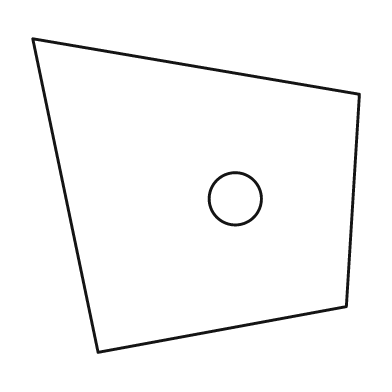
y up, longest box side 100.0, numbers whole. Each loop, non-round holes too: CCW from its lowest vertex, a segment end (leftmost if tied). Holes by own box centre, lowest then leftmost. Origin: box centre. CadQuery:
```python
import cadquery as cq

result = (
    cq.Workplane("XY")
    .moveTo(-30.0, -48.0)
    .lineTo(46.0, -34.0)
    .lineTo(50.0, 31.0)
    .lineTo(-50.0, 48.0)
    .close()
    .moveTo(12.0, -1.0)
    .circle(8.0)
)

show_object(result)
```